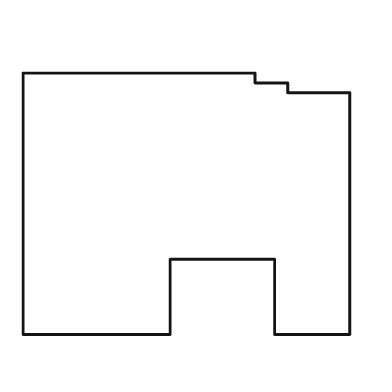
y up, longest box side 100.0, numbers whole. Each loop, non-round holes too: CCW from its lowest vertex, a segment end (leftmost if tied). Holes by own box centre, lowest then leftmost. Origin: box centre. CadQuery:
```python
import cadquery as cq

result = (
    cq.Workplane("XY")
    .moveTo(-50.0, -40.0)
    .lineTo(-5.0, -40.0)
    .lineTo(-5.0, -17.0)
    .lineTo(27.0, -17.0)
    .lineTo(27.0, -40.0)
    .lineTo(50.0, -40.0)
    .lineTo(50.0, 34.0)
    .lineTo(31.0, 34.0)
    .lineTo(31.0, 37.0)
    .lineTo(21.0, 37.0)
    .lineTo(21.0, 40.0)
    .lineTo(-50.0, 40.0)
    .close()
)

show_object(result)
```